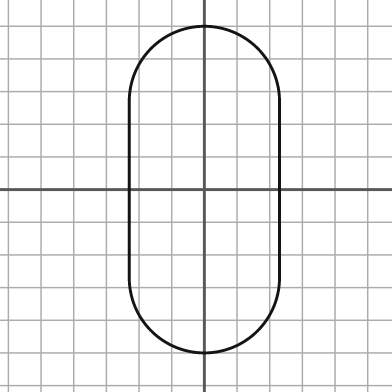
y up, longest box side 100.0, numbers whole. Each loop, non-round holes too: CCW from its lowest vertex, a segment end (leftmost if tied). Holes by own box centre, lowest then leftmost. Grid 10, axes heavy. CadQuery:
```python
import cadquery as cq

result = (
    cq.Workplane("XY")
    .moveTo(-23.0, -27.0)
    .threePointArc((0.0, -50.0), (23.0, -27.0))
    .lineTo(23.0, 27.0)
    .threePointArc((0.0, 50.0), (-23.0, 27.0))
    .close()
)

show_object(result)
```